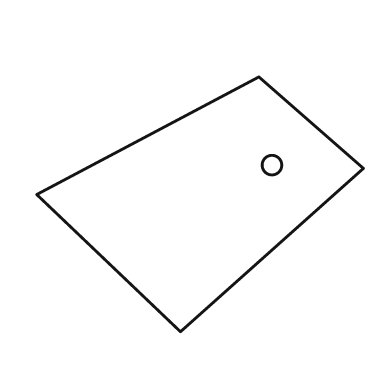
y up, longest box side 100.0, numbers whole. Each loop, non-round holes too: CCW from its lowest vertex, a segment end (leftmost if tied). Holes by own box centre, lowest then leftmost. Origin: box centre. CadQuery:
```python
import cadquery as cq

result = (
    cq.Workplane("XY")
    .moveTo(-6.0, -39.0)
    .lineTo(50.0, 11.0)
    .lineTo(18.0, 39.0)
    .lineTo(-50.0, 3.0)
    .close()
    .moveTo(22.0, 12.0)
    .circle(3.0)
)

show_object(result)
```